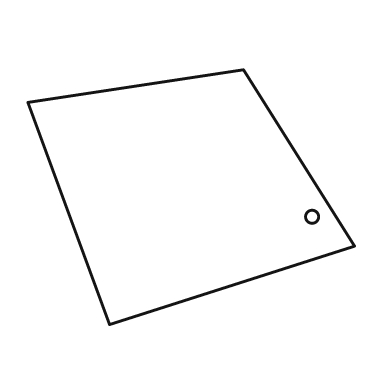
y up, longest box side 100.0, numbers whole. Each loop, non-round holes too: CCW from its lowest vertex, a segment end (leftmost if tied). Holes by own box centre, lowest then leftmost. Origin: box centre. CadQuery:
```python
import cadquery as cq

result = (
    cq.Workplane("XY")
    .moveTo(-25.0, -39.0)
    .lineTo(50.0, -15.0)
    .lineTo(16.0, 39.0)
    .lineTo(-50.0, 29.0)
    .close()
    .moveTo(37.0, -6.0)
    .circle(2.0)
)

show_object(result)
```